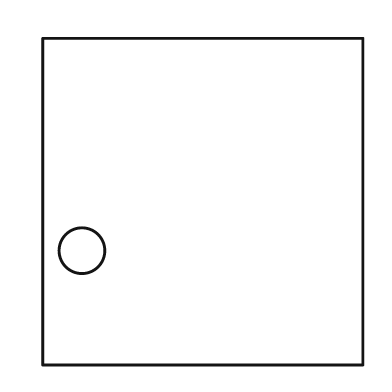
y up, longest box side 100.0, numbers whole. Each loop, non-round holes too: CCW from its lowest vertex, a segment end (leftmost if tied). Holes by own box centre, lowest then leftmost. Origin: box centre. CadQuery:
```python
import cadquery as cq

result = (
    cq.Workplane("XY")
    .moveTo(-49.0, -50.0)
    .lineTo(49.0, -50.0)
    .lineTo(49.0, 50.0)
    .lineTo(-49.0, 50.0)
    .close()
    .moveTo(-37.0, -15.0)
    .circle(7.0)
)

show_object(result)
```